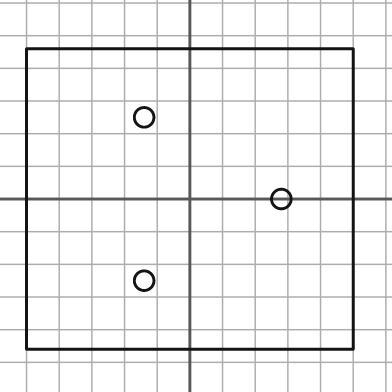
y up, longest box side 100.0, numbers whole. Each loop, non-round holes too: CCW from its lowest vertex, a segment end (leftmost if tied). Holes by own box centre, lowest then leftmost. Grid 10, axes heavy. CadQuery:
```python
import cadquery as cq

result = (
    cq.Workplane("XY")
    .moveTo(-50.0, -46.0)
    .lineTo(50.0, -46.0)
    .lineTo(50.0, 46.0)
    .lineTo(-50.0, 46.0)
    .close()
    .moveTo(-14.0, -25.0)
    .circle(3.0)
    .moveTo(28.0, 0.0)
    .circle(3.0)
    .moveTo(-14.0, 25.0)
    .circle(3.0)
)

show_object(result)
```